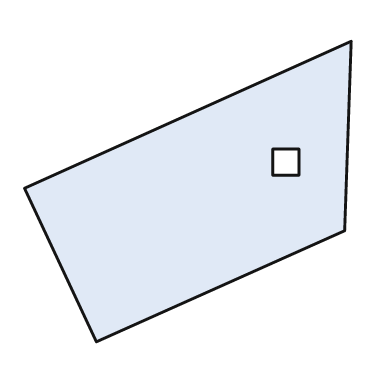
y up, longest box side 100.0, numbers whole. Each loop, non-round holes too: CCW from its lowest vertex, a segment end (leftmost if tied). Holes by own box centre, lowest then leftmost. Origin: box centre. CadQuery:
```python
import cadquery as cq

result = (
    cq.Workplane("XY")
    .moveTo(-28.0, -46.0)
    .lineTo(48.0, -12.0)
    .lineTo(50.0, 46.0)
    .lineTo(-50.0, 1.0)
    .close()
    .moveTo(26.0, 5.0)
    .lineTo(34.0, 5.0)
    .lineTo(34.0, 13.0)
    .lineTo(26.0, 13.0)
    .close()
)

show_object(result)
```